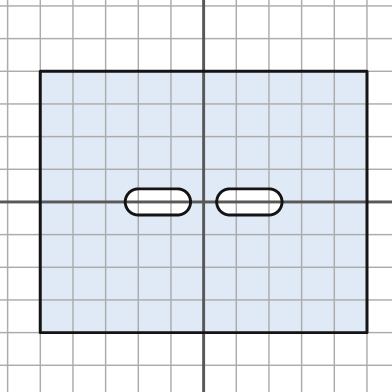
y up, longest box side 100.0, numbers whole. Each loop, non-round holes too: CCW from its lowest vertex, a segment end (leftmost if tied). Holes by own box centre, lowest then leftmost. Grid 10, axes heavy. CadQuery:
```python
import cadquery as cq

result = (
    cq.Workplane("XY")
    .moveTo(-50.0, -40.0)
    .lineTo(50.0, -40.0)
    .lineTo(50.0, 40.0)
    .lineTo(-50.0, 40.0)
    .close()
    .moveTo(-20.0, -4.0)
    .lineTo(-8.0, -4.0)
    .threePointArc((-4.0, 0.0), (-8.0, 4.0))
    .lineTo(-20.0, 4.0)
    .threePointArc((-24.0, 0.0), (-20.0, -4.0))
    .close()
    .moveTo(8.0, -4.0)
    .lineTo(20.0, -4.0)
    .threePointArc((24.0, 0.0), (20.0, 4.0))
    .lineTo(8.0, 4.0)
    .threePointArc((4.0, 0.0), (8.0, -4.0))
    .close()
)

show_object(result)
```